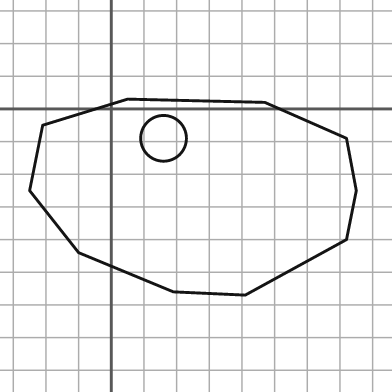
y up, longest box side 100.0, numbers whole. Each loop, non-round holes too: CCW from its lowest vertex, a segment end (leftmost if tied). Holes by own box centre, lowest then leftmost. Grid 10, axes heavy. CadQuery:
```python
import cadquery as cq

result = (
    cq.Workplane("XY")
    .moveTo(41.0, -57.0)
    .lineTo(72.0, -40.0)
    .lineTo(75.0, -25.0)
    .lineTo(72.0, -9.0)
    .lineTo(47.0, 2.0)
    .lineTo(5.0, 3.0)
    .lineTo(-21.0, -5.0)
    .lineTo(-25.0, -25.0)
    .lineTo(-10.0, -44.0)
    .lineTo(19.0, -56.0)
    .close()
    .moveTo(16.0, -9.0)
    .circle(7.0)
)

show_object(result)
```